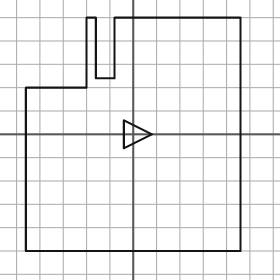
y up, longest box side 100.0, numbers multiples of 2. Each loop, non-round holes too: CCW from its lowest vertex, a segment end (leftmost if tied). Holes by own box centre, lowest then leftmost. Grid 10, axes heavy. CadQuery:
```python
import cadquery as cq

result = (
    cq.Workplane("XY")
    .moveTo(-46.0, -50.0)
    .lineTo(46.0, -50.0)
    .lineTo(46.0, 50.0)
    .lineTo(-8.0, 50.0)
    .lineTo(-8.0, 24.0)
    .lineTo(-16.0, 24.0)
    .lineTo(-16.0, 50.0)
    .lineTo(-20.0, 50.0)
    .lineTo(-20.0, 20.0)
    .lineTo(-46.0, 20.0)
    .close()
    .moveTo(-4.0, -6.0)
    .lineTo(8.0, 0.0)
    .lineTo(-4.0, 6.0)
    .close()
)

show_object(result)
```